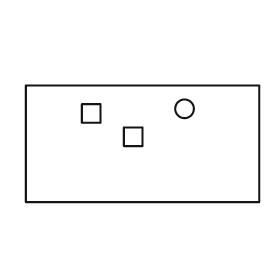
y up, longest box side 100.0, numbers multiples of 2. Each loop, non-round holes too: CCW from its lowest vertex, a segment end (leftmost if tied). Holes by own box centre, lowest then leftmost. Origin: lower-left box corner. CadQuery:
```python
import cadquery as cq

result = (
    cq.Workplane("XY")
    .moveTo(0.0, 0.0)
    .lineTo(100.0, 0.0)
    .lineTo(100.0, 50.0)
    .lineTo(0.0, 50.0)
    .close()
    .moveTo(42.0, 24.0)
    .lineTo(50.0, 24.0)
    .lineTo(50.0, 32.0)
    .lineTo(42.0, 32.0)
    .close()
    .moveTo(24.0, 34.0)
    .lineTo(32.0, 34.0)
    .lineTo(32.0, 42.0)
    .lineTo(24.0, 42.0)
    .close()
    .moveTo(68.0, 40.0)
    .circle(4.0)
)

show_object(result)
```